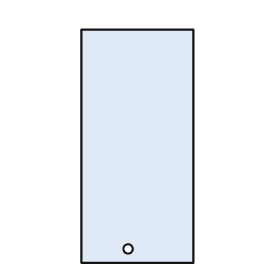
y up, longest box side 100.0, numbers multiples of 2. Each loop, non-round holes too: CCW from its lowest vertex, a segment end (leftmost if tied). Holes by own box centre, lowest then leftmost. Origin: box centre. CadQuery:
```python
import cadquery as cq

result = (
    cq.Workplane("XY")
    .moveTo(-24.0, -50.0)
    .lineTo(24.0, -50.0)
    .lineTo(24.0, 50.0)
    .lineTo(-24.0, 50.0)
    .close()
    .moveTo(-4.0, -44.0)
    .circle(2.0)
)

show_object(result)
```